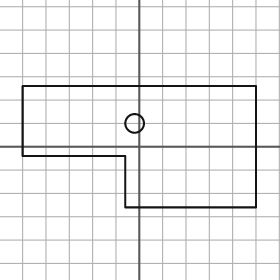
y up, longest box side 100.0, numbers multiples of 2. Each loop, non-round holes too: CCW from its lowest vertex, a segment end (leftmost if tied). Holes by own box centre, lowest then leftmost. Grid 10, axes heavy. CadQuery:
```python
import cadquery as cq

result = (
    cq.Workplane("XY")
    .moveTo(-6.0, -26.0)
    .lineTo(50.0, -26.0)
    .lineTo(50.0, 26.0)
    .lineTo(-50.0, 26.0)
    .lineTo(-50.0, -4.0)
    .lineTo(-6.0, -4.0)
    .close()
    .moveTo(-2.0, 10.0)
    .circle(4.0)
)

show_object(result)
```